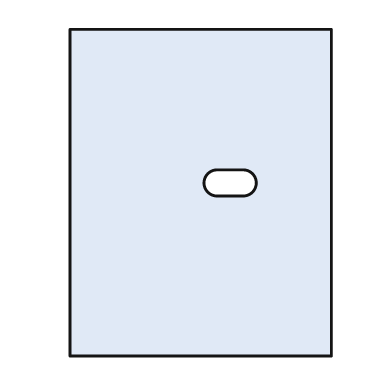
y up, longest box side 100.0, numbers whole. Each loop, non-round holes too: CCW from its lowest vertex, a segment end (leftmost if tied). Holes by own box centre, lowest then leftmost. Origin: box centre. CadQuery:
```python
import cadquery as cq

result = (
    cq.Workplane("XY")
    .moveTo(-40.0, -50.0)
    .lineTo(40.0, -50.0)
    .lineTo(40.0, 50.0)
    .lineTo(-40.0, 50.0)
    .close()
    .moveTo(5.0, -1.0)
    .lineTo(13.0, -1.0)
    .threePointArc((17.0, 3.0), (13.0, 7.0))
    .lineTo(5.0, 7.0)
    .threePointArc((1.0, 3.0), (5.0, -1.0))
    .close()
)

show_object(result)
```